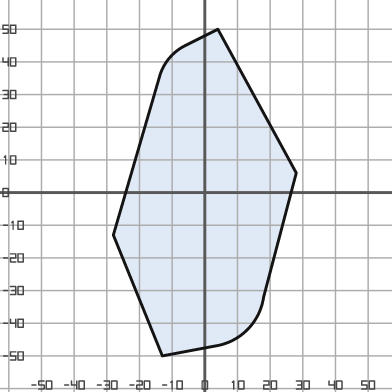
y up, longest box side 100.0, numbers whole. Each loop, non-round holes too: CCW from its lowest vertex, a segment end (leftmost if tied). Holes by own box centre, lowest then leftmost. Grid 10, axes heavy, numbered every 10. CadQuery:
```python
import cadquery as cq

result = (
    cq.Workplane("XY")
    .moveTo(-13.0, -50.0)
    .lineTo(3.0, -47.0)
    .threePointArc((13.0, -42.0), (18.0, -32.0))
    .lineTo(28.0, 6.0)
    .lineTo(4.0, 50.0)
    .lineTo(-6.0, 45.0)
    .threePointArc((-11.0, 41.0), (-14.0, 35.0))
    .lineTo(-28.0, -13.0)
    .close()
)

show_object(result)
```